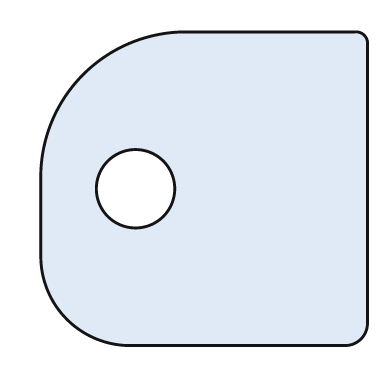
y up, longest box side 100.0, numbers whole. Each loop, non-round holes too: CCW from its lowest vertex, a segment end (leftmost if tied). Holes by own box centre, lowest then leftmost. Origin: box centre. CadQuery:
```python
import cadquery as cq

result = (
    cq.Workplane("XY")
    .moveTo(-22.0, -48.0)
    .lineTo(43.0, -48.0)
    .threePointArc((48.0, -46.0), (50.0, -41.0))
    .lineTo(50.0, 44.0)
    .threePointArc((49.0, 47.0), (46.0, 48.0))
    .lineTo(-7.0, 48.0)
    .threePointArc((-37.0, 35.0), (-50.0, 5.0))
    .lineTo(-50.0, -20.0)
    .threePointArc((-42.0, -40.0), (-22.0, -48.0))
    .close()
    .moveTo(-21.0, 0.0)
    .circle(12.0)
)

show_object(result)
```